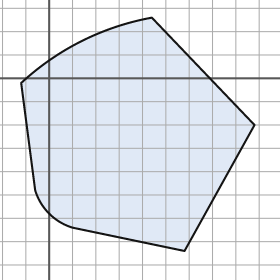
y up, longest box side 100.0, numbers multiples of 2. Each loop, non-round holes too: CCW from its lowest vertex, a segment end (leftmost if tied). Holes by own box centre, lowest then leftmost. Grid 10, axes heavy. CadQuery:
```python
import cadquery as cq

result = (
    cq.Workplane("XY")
    .moveTo(58.0, -74.0)
    .lineTo(88.0, -20.0)
    .lineTo(44.0, 26.0)
    .threePointArc((14.0, 16.0), (-12.0, -2.0))
    .lineTo(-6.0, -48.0)
    .threePointArc((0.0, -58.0), (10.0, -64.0))
    .close()
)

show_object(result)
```